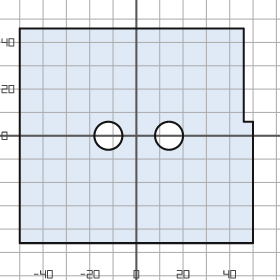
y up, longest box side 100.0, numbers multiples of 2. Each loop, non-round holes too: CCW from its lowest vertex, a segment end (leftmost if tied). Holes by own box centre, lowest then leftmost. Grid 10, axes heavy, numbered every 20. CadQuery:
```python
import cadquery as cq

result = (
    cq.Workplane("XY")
    .moveTo(-50.0, -46.0)
    .lineTo(50.0, -46.0)
    .lineTo(50.0, 6.0)
    .lineTo(46.0, 6.0)
    .lineTo(46.0, 46.0)
    .lineTo(-50.0, 46.0)
    .close()
    .moveTo(-12.0, 0.0)
    .circle(6.0)
    .moveTo(14.0, 0.0)
    .circle(6.0)
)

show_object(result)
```